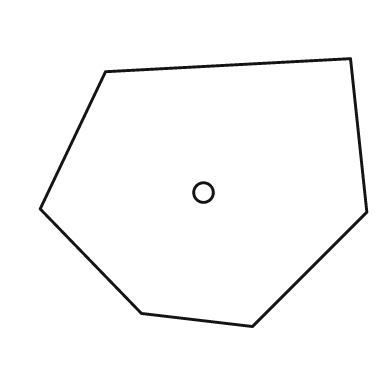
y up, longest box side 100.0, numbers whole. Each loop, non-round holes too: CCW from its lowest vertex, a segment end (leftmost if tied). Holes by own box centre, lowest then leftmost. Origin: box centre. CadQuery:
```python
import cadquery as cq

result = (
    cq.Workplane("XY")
    .moveTo(15.0, -41.0)
    .lineTo(50.0, -6.0)
    .lineTo(45.0, 41.0)
    .lineTo(-30.0, 37.0)
    .lineTo(-50.0, -5.0)
    .lineTo(-19.0, -37.0)
    .close()
    .moveTo(0.0, 0.0)
    .circle(3.0)
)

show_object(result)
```